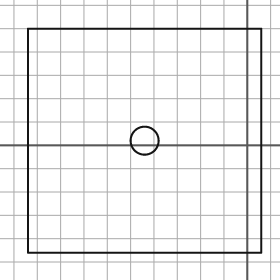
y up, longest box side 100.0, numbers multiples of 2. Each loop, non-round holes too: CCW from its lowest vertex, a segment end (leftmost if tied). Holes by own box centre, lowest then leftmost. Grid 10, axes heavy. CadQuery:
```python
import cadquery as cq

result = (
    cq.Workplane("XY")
    .moveTo(-94.0, -46.0)
    .lineTo(6.0, -46.0)
    .lineTo(6.0, 50.0)
    .lineTo(-94.0, 50.0)
    .close()
    .moveTo(-44.0, 2.0)
    .circle(6.0)
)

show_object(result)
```